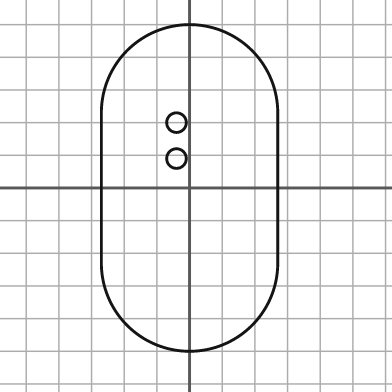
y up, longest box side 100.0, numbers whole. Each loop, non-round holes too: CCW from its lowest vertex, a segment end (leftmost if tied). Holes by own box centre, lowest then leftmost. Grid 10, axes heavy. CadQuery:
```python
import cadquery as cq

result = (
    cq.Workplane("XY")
    .moveTo(-27.0, -23.0)
    .threePointArc((0.0, -50.0), (27.0, -23.0))
    .lineTo(27.0, 23.0)
    .threePointArc((0.0, 50.0), (-27.0, 23.0))
    .close()
    .moveTo(-4.0, 9.0)
    .circle(3.0)
    .moveTo(-4.0, 20.0)
    .circle(3.0)
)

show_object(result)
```